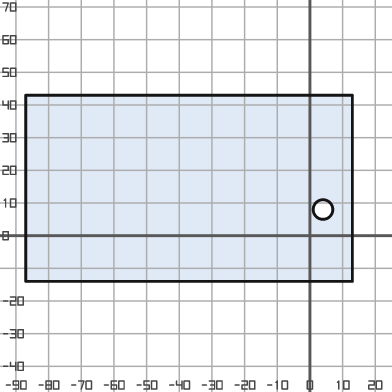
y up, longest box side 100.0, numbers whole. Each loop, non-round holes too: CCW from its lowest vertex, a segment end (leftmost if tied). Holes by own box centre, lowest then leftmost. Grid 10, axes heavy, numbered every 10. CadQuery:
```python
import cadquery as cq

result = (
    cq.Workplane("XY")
    .moveTo(-87.0, -14.0)
    .lineTo(13.0, -14.0)
    .lineTo(13.0, 43.0)
    .lineTo(-87.0, 43.0)
    .close()
    .moveTo(4.0, 8.0)
    .circle(3.0)
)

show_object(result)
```